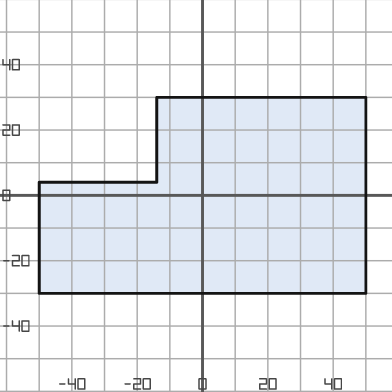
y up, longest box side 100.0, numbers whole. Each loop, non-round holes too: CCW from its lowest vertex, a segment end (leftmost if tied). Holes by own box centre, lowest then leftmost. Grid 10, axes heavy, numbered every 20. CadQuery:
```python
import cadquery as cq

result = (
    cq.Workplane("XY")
    .moveTo(-50.0, -30.0)
    .lineTo(50.0, -30.0)
    .lineTo(50.0, 30.0)
    .lineTo(-14.0, 30.0)
    .lineTo(-14.0, 4.0)
    .lineTo(-50.0, 4.0)
    .close()
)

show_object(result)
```